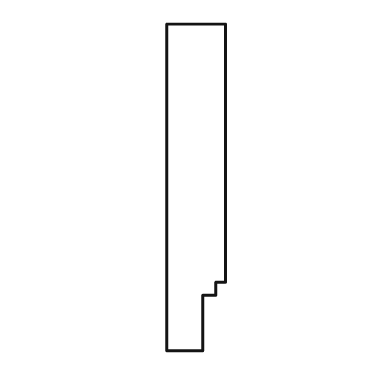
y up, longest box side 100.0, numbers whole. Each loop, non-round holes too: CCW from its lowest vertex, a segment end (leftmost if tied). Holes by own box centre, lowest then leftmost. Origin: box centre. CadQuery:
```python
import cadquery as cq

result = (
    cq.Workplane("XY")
    .moveTo(-9.0, -50.0)
    .lineTo(2.0, -50.0)
    .lineTo(2.0, -33.0)
    .lineTo(6.0, -33.0)
    .lineTo(6.0, -29.0)
    .lineTo(9.0, -29.0)
    .lineTo(9.0, 50.0)
    .lineTo(-9.0, 50.0)
    .close()
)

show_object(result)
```